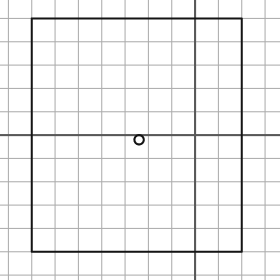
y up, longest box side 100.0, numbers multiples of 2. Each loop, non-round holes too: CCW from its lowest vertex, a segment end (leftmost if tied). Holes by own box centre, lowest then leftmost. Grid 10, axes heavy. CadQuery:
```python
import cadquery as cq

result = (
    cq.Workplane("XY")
    .moveTo(-70.0, -50.0)
    .lineTo(20.0, -50.0)
    .lineTo(20.0, 50.0)
    .lineTo(-70.0, 50.0)
    .close()
    .moveTo(-24.0, -2.0)
    .circle(2.0)
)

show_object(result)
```